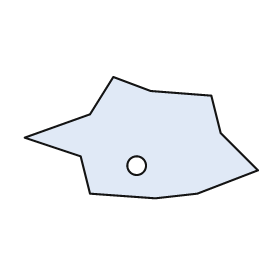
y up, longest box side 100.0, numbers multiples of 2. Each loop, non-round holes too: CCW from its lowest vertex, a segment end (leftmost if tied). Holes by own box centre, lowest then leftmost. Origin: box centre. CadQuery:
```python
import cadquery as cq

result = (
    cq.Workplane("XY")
    .moveTo(6.0, -26.0)
    .lineTo(24.0, -24.0)
    .lineTo(50.0, -14.0)
    .lineTo(34.0, 2.0)
    .lineTo(30.0, 18.0)
    .lineTo(4.0, 20.0)
    .lineTo(-12.0, 26.0)
    .lineTo(-22.0, 10.0)
    .lineTo(-50.0, 0.0)
    .lineTo(-26.0, -8.0)
    .lineTo(-22.0, -24.0)
    .close()
    .moveTo(-2.0, -12.0)
    .circle(4.0)
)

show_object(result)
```